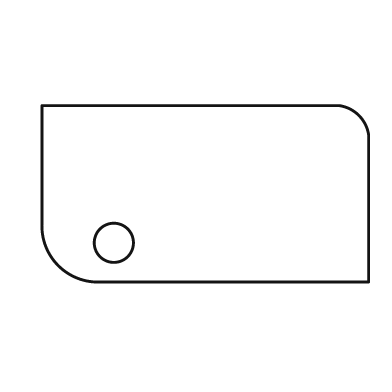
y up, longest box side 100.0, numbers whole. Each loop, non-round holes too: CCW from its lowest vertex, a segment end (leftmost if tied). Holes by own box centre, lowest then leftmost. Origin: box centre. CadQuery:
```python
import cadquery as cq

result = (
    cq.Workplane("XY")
    .moveTo(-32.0, -27.0)
    .lineTo(50.0, -27.0)
    .lineTo(50.0, 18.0)
    .threePointArc((47.0, 24.0), (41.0, 27.0))
    .lineTo(-50.0, 27.0)
    .lineTo(-50.0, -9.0)
    .threePointArc((-45.0, -22.0), (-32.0, -27.0))
    .close()
    .moveTo(-28.0, -15.0)
    .circle(6.0)
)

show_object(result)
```